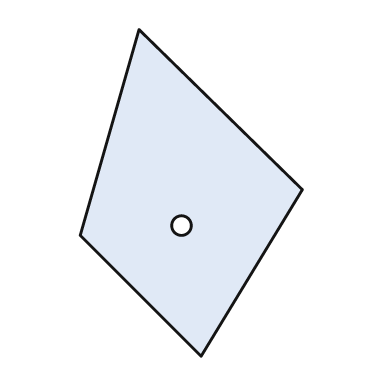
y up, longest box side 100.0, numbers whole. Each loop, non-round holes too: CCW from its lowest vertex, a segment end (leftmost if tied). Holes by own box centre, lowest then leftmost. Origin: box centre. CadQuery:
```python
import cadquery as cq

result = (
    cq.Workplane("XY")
    .moveTo(3.0, -50.0)
    .lineTo(34.0, 1.0)
    .lineTo(-16.0, 50.0)
    .lineTo(-34.0, -13.0)
    .close()
    .moveTo(-3.0, -10.0)
    .circle(3.0)
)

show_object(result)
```